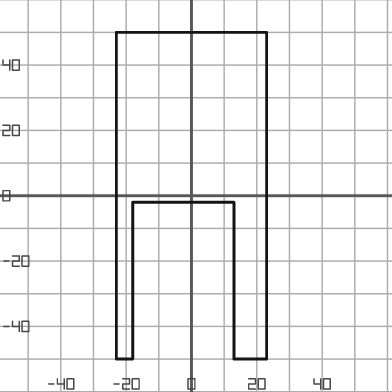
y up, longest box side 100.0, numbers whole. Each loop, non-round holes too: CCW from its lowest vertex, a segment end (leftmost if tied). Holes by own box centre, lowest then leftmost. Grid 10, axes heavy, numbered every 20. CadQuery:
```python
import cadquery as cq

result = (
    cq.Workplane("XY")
    .moveTo(-23.0, -50.0)
    .lineTo(-18.0, -50.0)
    .lineTo(-18.0, -2.0)
    .lineTo(13.0, -2.0)
    .lineTo(13.0, -50.0)
    .lineTo(23.0, -50.0)
    .lineTo(23.0, 50.0)
    .lineTo(-23.0, 50.0)
    .close()
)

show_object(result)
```